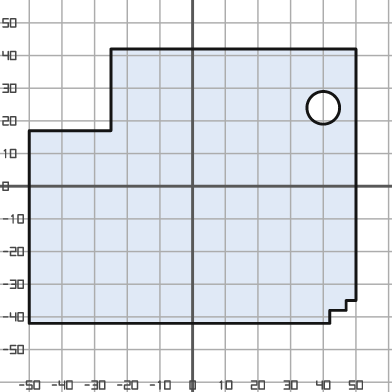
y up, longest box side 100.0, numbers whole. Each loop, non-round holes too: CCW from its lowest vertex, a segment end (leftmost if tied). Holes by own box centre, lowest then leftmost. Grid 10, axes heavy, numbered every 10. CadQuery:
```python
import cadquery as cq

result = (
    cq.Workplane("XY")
    .moveTo(-50.0, -42.0)
    .lineTo(42.0, -42.0)
    .lineTo(42.0, -38.0)
    .lineTo(47.0, -38.0)
    .lineTo(47.0, -35.0)
    .lineTo(50.0, -35.0)
    .lineTo(50.0, 42.0)
    .lineTo(-25.0, 42.0)
    .lineTo(-25.0, 17.0)
    .lineTo(-50.0, 17.0)
    .close()
    .moveTo(40.0, 24.0)
    .circle(5.0)
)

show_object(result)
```